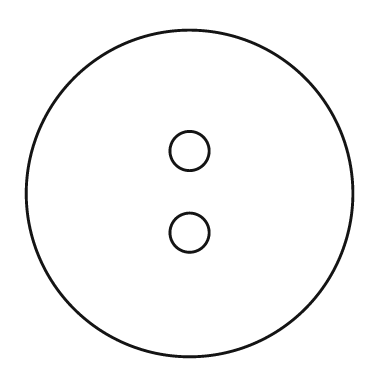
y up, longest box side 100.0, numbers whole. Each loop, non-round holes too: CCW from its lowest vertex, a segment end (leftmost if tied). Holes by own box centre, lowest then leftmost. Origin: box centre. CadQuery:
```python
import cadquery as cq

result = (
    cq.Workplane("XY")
    .moveTo(0.0, 0.0)
    .circle(50.0)
    .moveTo(0.0, -12.0)
    .circle(6.0)
    .moveTo(0.0, 13.0)
    .circle(6.0)
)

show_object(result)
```